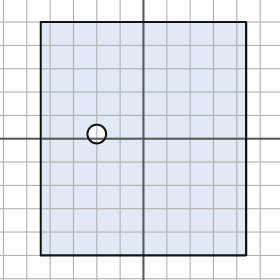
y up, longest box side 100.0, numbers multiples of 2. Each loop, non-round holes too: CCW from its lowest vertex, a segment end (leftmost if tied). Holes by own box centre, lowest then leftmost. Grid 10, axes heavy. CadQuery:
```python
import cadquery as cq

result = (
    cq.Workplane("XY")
    .moveTo(-44.0, -50.0)
    .lineTo(44.0, -50.0)
    .lineTo(44.0, 50.0)
    .lineTo(-44.0, 50.0)
    .close()
    .moveTo(-20.0, 2.0)
    .circle(4.0)
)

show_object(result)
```